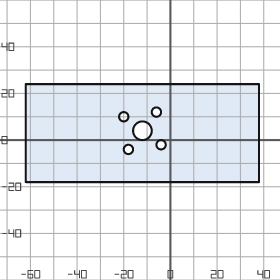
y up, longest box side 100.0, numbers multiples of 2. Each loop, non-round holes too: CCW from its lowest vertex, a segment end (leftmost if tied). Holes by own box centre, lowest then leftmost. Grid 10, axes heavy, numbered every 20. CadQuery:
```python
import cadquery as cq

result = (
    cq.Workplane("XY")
    .moveTo(-62.0, -18.0)
    .lineTo(38.0, -18.0)
    .lineTo(38.0, 24.0)
    .lineTo(-62.0, 24.0)
    .close()
    .moveTo(-18.0, -4.0)
    .circle(2.0)
    .moveTo(-4.0, -2.0)
    .circle(2.0)
    .moveTo(-12.0, 4.0)
    .circle(4.0)
    .moveTo(-20.0, 10.0)
    .circle(2.0)
    .moveTo(-6.0, 12.0)
    .circle(2.0)
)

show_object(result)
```